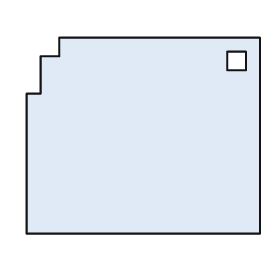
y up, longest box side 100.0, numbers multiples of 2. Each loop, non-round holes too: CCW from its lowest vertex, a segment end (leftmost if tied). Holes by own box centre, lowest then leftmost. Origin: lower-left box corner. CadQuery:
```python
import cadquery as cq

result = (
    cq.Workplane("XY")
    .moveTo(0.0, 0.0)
    .lineTo(100.0, 0.0)
    .lineTo(100.0, 84.0)
    .lineTo(14.0, 84.0)
    .lineTo(14.0, 76.0)
    .lineTo(6.0, 76.0)
    .lineTo(6.0, 60.0)
    .lineTo(0.0, 60.0)
    .close()
    .moveTo(86.0, 70.0)
    .lineTo(94.0, 70.0)
    .lineTo(94.0, 78.0)
    .lineTo(86.0, 78.0)
    .close()
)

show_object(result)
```